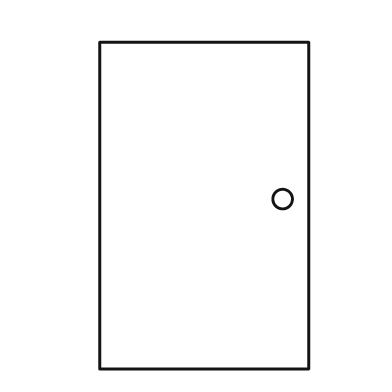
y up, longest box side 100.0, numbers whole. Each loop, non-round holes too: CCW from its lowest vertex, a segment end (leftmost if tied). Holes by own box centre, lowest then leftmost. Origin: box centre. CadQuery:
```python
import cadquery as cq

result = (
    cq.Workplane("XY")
    .moveTo(-32.0, -50.0)
    .lineTo(32.0, -50.0)
    .lineTo(32.0, 50.0)
    .lineTo(-32.0, 50.0)
    .close()
    .moveTo(24.0, 2.0)
    .circle(3.0)
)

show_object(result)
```